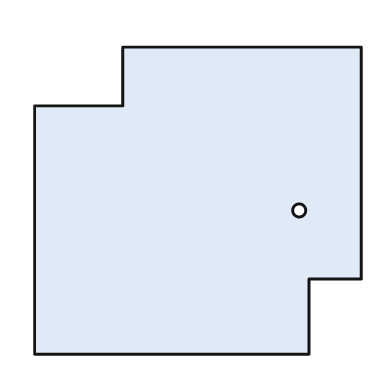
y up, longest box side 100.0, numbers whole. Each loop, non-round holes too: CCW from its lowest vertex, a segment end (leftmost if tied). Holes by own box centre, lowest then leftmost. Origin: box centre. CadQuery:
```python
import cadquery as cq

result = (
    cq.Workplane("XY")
    .moveTo(-50.0, -47.0)
    .lineTo(34.0, -47.0)
    .lineTo(34.0, -24.0)
    .lineTo(50.0, -24.0)
    .lineTo(50.0, 47.0)
    .lineTo(-23.0, 47.0)
    .lineTo(-23.0, 29.0)
    .lineTo(-50.0, 29.0)
    .close()
    .moveTo(31.0, -3.0)
    .circle(2.0)
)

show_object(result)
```